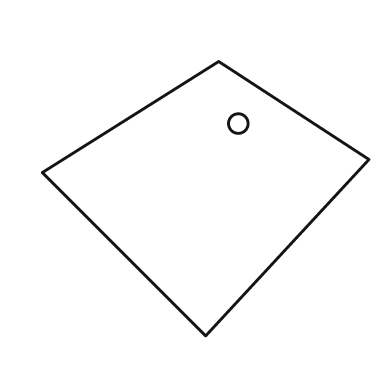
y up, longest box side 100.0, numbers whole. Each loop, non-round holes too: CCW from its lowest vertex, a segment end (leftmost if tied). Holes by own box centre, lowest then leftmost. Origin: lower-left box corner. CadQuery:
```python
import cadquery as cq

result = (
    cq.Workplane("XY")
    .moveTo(50.0, 0.0)
    .lineTo(100.0, 54.0)
    .lineTo(54.0, 84.0)
    .lineTo(0.0, 50.0)
    .close()
    .moveTo(60.0, 65.0)
    .circle(3.0)
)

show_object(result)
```